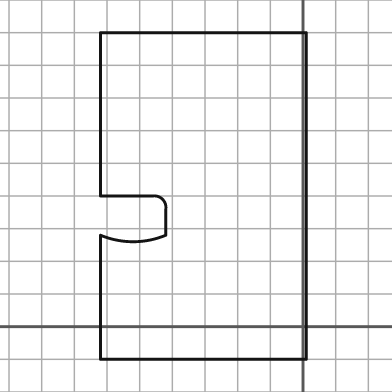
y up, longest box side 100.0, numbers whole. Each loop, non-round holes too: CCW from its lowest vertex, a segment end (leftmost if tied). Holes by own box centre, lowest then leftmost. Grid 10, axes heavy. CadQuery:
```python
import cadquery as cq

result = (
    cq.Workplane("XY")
    .moveTo(-62.0, -10.0)
    .lineTo(1.0, -10.0)
    .lineTo(1.0, 90.0)
    .lineTo(-62.0, 90.0)
    .lineTo(-62.0, 40.0)
    .lineTo(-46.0, 40.0)
    .threePointArc((-43.0, 39.0), (-42.0, 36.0))
    .lineTo(-42.0, 28.0)
    .threePointArc((-52.0, 26.0), (-62.0, 28.0))
    .close()
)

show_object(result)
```